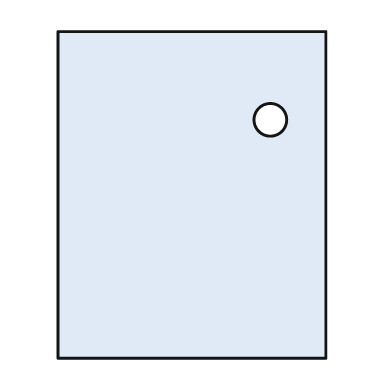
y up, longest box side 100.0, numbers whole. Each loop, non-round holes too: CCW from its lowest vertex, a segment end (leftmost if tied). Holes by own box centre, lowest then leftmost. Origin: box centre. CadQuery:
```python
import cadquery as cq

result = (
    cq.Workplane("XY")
    .moveTo(-41.0, -50.0)
    .lineTo(41.0, -50.0)
    .lineTo(41.0, 50.0)
    .lineTo(-41.0, 50.0)
    .close()
    .moveTo(24.0, 23.0)
    .circle(5.0)
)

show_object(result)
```